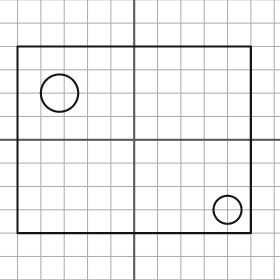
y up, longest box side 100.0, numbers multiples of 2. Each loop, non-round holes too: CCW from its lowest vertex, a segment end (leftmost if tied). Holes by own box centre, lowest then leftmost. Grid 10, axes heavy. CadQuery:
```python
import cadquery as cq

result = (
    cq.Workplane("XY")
    .moveTo(-50.0, -40.0)
    .lineTo(50.0, -40.0)
    .lineTo(50.0, 40.0)
    .lineTo(-50.0, 40.0)
    .close()
    .moveTo(40.0, -30.0)
    .circle(6.0)
    .moveTo(-32.0, 20.0)
    .circle(8.0)
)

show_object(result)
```